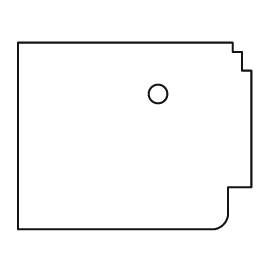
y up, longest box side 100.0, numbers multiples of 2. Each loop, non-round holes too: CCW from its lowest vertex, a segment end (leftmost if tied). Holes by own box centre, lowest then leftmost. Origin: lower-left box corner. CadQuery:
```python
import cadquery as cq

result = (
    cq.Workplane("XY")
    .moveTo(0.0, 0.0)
    .lineTo(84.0, 0.0)
    .threePointArc((88.0, 2.0), (90.0, 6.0))
    .lineTo(90.0, 18.0)
    .lineTo(100.0, 18.0)
    .lineTo(100.0, 68.0)
    .lineTo(96.0, 68.0)
    .lineTo(96.0, 76.0)
    .lineTo(92.0, 76.0)
    .lineTo(92.0, 80.0)
    .lineTo(0.0, 80.0)
    .close()
    .moveTo(60.0, 58.0)
    .circle(4.0)
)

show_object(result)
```